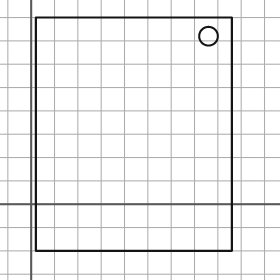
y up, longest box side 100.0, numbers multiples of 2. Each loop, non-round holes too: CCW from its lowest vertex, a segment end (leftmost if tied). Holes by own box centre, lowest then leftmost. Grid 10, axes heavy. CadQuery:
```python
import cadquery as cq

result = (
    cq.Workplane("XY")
    .moveTo(2.0, -20.0)
    .lineTo(86.0, -20.0)
    .lineTo(86.0, 80.0)
    .lineTo(2.0, 80.0)
    .close()
    .moveTo(76.0, 72.0)
    .circle(4.0)
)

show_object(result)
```